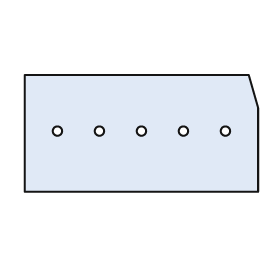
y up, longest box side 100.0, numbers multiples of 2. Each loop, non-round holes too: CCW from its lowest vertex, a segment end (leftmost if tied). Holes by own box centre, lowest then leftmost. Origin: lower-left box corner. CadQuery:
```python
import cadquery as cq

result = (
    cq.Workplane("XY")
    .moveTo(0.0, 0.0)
    .lineTo(100.0, 0.0)
    .lineTo(100.0, 36.0)
    .lineTo(96.0, 50.0)
    .lineTo(0.0, 50.0)
    .close()
    .moveTo(14.0, 26.0)
    .circle(2.0)
    .moveTo(32.0, 26.0)
    .circle(2.0)
    .moveTo(50.0, 26.0)
    .circle(2.0)
    .moveTo(68.0, 26.0)
    .circle(2.0)
    .moveTo(86.0, 26.0)
    .circle(2.0)
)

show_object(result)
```